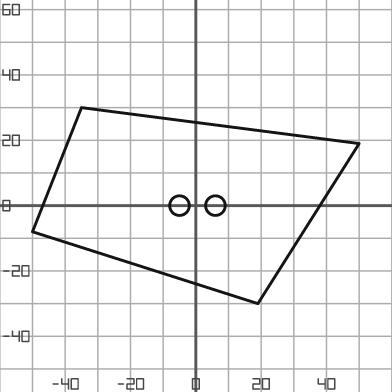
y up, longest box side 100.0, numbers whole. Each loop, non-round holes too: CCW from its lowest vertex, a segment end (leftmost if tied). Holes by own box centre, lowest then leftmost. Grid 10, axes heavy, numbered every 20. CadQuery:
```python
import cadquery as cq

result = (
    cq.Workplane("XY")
    .moveTo(19.0, -30.0)
    .lineTo(50.0, 19.0)
    .lineTo(-35.0, 30.0)
    .lineTo(-50.0, -8.0)
    .close()
    .moveTo(-5.0, 0.0)
    .circle(3.0)
    .moveTo(6.0, 0.0)
    .circle(3.0)
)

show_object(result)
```